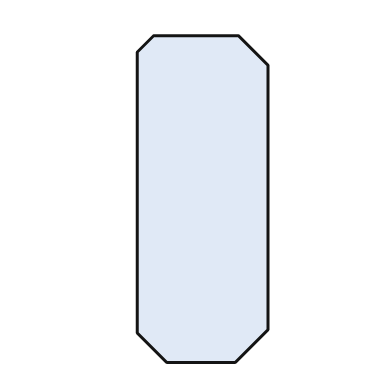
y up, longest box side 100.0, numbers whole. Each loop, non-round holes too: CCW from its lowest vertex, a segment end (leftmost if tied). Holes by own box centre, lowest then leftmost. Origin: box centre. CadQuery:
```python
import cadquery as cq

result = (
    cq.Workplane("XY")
    .moveTo(-11.0, -50.0)
    .lineTo(10.0, -50.0)
    .lineTo(20.0, -40.0)
    .lineTo(20.0, 41.0)
    .lineTo(11.0, 50.0)
    .lineTo(-15.0, 50.0)
    .lineTo(-20.0, 45.0)
    .lineTo(-20.0, -41.0)
    .close()
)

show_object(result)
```